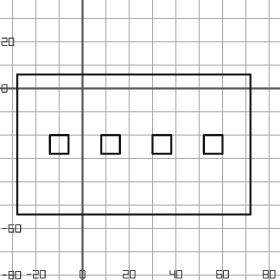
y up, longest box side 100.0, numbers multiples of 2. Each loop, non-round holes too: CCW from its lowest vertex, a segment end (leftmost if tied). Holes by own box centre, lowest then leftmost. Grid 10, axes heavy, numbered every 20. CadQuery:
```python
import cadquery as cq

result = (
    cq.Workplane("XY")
    .moveTo(-28.0, -54.0)
    .lineTo(72.0, -54.0)
    .lineTo(72.0, 6.0)
    .lineTo(-28.0, 6.0)
    .close()
    .moveTo(-14.0, -28.0)
    .lineTo(-6.0, -28.0)
    .lineTo(-6.0, -20.0)
    .lineTo(-14.0, -20.0)
    .close()
    .moveTo(8.0, -28.0)
    .lineTo(16.0, -28.0)
    .lineTo(16.0, -20.0)
    .lineTo(8.0, -20.0)
    .close()
    .moveTo(30.0, -28.0)
    .lineTo(38.0, -28.0)
    .lineTo(38.0, -20.0)
    .lineTo(30.0, -20.0)
    .close()
    .moveTo(52.0, -28.0)
    .lineTo(60.0, -28.0)
    .lineTo(60.0, -20.0)
    .lineTo(52.0, -20.0)
    .close()
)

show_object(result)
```